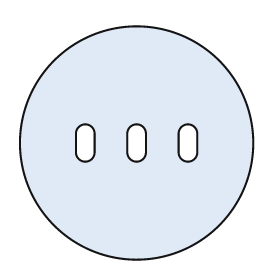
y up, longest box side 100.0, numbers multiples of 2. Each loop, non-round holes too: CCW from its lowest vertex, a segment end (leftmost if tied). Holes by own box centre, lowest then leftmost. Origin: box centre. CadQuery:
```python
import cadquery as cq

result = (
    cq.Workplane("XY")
    .moveTo(0.0, 0.0)
    .circle(50.0)
    .moveTo(-26.0, -4.0)
    .threePointArc((-22.0, -8.0), (-18.0, -4.0))
    .lineTo(-18.0, 4.0)
    .threePointArc((-22.0, 8.0), (-26.0, 4.0))
    .close()
    .moveTo(-4.0, -4.0)
    .threePointArc((0.0, -8.0), (4.0, -4.0))
    .lineTo(4.0, 4.0)
    .threePointArc((0.0, 8.0), (-4.0, 4.0))
    .close()
    .moveTo(18.0, -4.0)
    .threePointArc((22.0, -8.0), (26.0, -4.0))
    .lineTo(26.0, 4.0)
    .threePointArc((22.0, 8.0), (18.0, 4.0))
    .close()
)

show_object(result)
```